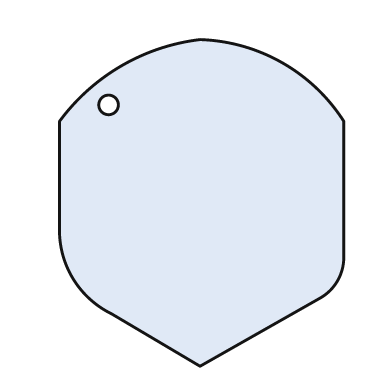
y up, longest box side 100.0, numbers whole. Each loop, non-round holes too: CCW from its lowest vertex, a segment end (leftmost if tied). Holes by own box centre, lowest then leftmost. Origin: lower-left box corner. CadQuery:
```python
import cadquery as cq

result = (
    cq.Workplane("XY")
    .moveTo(43.0, 0.0)
    .lineTo(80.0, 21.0)
    .threePointArc((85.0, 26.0), (87.0, 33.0))
    .lineTo(87.0, 75.0)
    .threePointArc((68.0, 93.0), (43.0, 100.0))
    .threePointArc((19.0, 92.0), (0.0, 75.0))
    .lineTo(0.0, 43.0)
    .threePointArc((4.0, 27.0), (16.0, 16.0))
    .close()
    .moveTo(15.0, 80.0)
    .circle(3.0)
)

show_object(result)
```